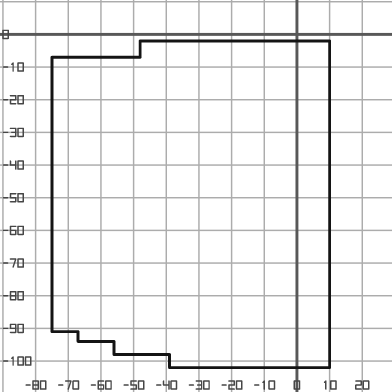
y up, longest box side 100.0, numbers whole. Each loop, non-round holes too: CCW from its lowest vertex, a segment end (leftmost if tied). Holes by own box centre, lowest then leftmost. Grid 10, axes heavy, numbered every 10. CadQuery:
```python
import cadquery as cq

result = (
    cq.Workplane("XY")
    .moveTo(-39.0, -102.0)
    .lineTo(10.0, -102.0)
    .lineTo(10.0, -2.0)
    .lineTo(-48.0, -2.0)
    .lineTo(-48.0, -7.0)
    .lineTo(-75.0, -7.0)
    .lineTo(-75.0, -91.0)
    .lineTo(-67.0, -91.0)
    .lineTo(-67.0, -94.0)
    .lineTo(-56.0, -94.0)
    .lineTo(-56.0, -98.0)
    .lineTo(-39.0, -98.0)
    .close()
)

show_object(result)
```